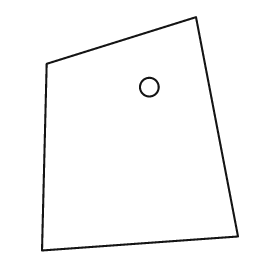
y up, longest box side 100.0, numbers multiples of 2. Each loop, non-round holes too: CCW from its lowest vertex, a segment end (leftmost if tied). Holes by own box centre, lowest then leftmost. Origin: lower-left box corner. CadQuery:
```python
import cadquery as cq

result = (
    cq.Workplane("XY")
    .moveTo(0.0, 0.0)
    .lineTo(84.0, 6.0)
    .lineTo(66.0, 100.0)
    .lineTo(2.0, 80.0)
    .close()
    .moveTo(46.0, 70.0)
    .circle(4.0)
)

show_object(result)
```